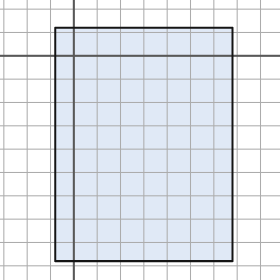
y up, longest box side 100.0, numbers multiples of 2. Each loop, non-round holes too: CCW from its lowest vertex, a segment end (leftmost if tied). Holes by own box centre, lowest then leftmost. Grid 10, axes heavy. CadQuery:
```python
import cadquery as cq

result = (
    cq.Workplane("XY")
    .moveTo(-8.0, -88.0)
    .lineTo(68.0, -88.0)
    .lineTo(68.0, 12.0)
    .lineTo(-8.0, 12.0)
    .close()
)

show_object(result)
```